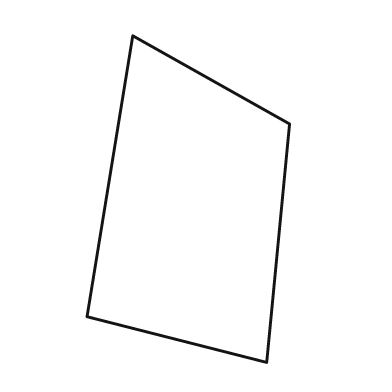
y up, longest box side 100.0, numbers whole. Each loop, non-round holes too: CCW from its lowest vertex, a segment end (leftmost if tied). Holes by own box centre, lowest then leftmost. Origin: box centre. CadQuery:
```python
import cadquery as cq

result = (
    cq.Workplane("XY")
    .moveTo(24.0, -50.0)
    .lineTo(31.0, 23.0)
    .lineTo(-17.0, 50.0)
    .lineTo(-31.0, -36.0)
    .close()
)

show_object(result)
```